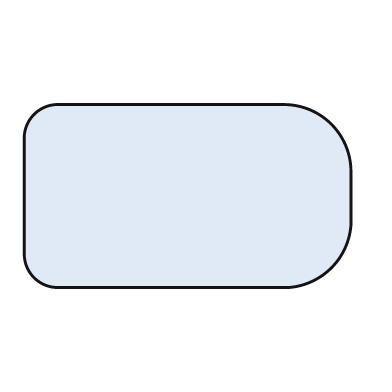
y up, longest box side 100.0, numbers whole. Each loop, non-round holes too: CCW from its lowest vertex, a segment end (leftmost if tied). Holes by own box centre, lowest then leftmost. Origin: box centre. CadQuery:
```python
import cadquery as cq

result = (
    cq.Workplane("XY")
    .moveTo(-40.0, -28.0)
    .lineTo(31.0, -28.0)
    .threePointArc((44.0, -22.0), (50.0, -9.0))
    .lineTo(50.0, 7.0)
    .threePointArc((44.0, 22.0), (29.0, 28.0))
    .lineTo(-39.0, 28.0)
    .threePointArc((-47.0, 25.0), (-50.0, 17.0))
    .lineTo(-50.0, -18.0)
    .threePointArc((-47.0, -25.0), (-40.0, -28.0))
    .close()
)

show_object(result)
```